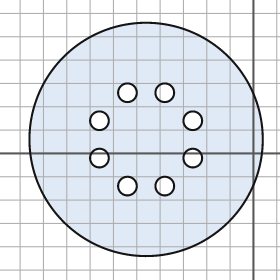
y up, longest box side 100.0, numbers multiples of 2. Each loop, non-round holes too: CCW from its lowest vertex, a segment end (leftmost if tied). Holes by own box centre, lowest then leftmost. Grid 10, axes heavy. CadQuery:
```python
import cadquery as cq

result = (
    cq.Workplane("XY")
    .moveTo(-46.0, 6.0)
    .circle(50.0)
    .moveTo(-54.0, -14.0)
    .circle(4.0)
    .moveTo(-38.0, -14.0)
    .circle(4.0)
    .moveTo(-66.0, -2.0)
    .circle(4.0)
    .moveTo(-26.0, -2.0)
    .circle(4.0)
    .moveTo(-66.0, 14.0)
    .circle(4.0)
    .moveTo(-26.0, 14.0)
    .circle(4.0)
    .moveTo(-54.0, 26.0)
    .circle(4.0)
    .moveTo(-38.0, 26.0)
    .circle(4.0)
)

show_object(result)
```